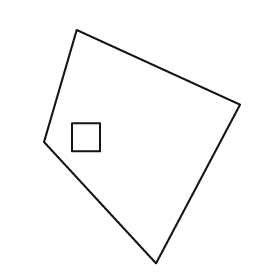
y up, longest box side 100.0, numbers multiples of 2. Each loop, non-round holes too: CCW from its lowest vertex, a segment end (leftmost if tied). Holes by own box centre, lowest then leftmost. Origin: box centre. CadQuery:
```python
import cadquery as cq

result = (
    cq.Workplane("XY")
    .moveTo(6.0, -50.0)
    .lineTo(42.0, 18.0)
    .lineTo(-28.0, 50.0)
    .lineTo(-42.0, 2.0)
    .close()
    .moveTo(-30.0, -2.0)
    .lineTo(-18.0, -2.0)
    .lineTo(-18.0, 10.0)
    .lineTo(-30.0, 10.0)
    .close()
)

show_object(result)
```